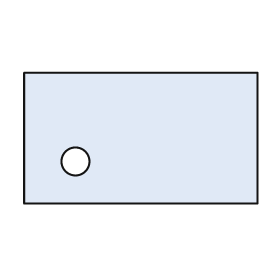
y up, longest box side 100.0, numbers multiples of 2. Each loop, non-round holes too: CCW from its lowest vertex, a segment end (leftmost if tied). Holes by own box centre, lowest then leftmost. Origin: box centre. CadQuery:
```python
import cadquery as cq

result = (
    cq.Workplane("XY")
    .moveTo(-50.0, -28.0)
    .lineTo(50.0, -28.0)
    .lineTo(50.0, 28.0)
    .lineTo(-50.0, 28.0)
    .close()
    .moveTo(-28.0, -10.0)
    .circle(6.0)
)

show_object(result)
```